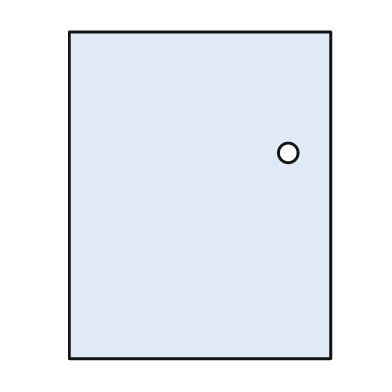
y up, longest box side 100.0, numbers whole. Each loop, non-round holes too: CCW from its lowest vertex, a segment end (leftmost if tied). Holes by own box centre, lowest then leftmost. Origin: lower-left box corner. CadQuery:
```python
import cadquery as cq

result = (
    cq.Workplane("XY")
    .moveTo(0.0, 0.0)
    .lineTo(80.0, 0.0)
    .lineTo(80.0, 100.0)
    .lineTo(0.0, 100.0)
    .close()
    .moveTo(67.0, 63.0)
    .circle(3.0)
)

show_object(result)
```